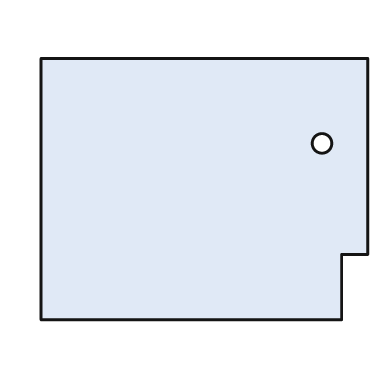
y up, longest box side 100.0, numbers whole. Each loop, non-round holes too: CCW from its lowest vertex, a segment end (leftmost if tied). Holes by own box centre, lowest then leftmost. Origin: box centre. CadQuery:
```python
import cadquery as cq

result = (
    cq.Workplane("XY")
    .moveTo(-50.0, -40.0)
    .lineTo(42.0, -40.0)
    .lineTo(42.0, -20.0)
    .lineTo(50.0, -20.0)
    .lineTo(50.0, 40.0)
    .lineTo(-50.0, 40.0)
    .close()
    .moveTo(36.0, 14.0)
    .circle(3.0)
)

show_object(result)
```